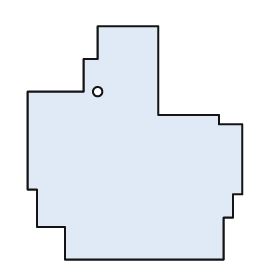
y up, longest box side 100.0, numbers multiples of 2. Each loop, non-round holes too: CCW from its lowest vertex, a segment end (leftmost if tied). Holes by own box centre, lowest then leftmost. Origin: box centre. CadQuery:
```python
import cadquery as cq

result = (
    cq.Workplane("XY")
    .moveTo(-30.0, -50.0)
    .lineTo(38.0, -50.0)
    .lineTo(38.0, -32.0)
    .lineTo(42.0, -32.0)
    .lineTo(42.0, -22.0)
    .lineTo(46.0, -22.0)
    .lineTo(46.0, 8.0)
    .lineTo(36.0, 8.0)
    .lineTo(36.0, 12.0)
    .lineTo(10.0, 12.0)
    .lineTo(10.0, 50.0)
    .lineTo(-16.0, 50.0)
    .lineTo(-16.0, 36.0)
    .lineTo(-22.0, 36.0)
    .lineTo(-22.0, 22.0)
    .lineTo(-46.0, 22.0)
    .lineTo(-46.0, -20.0)
    .lineTo(-42.0, -20.0)
    .lineTo(-42.0, -36.0)
    .lineTo(-30.0, -36.0)
    .close()
    .moveTo(-16.0, 22.0)
    .circle(2.0)
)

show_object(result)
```